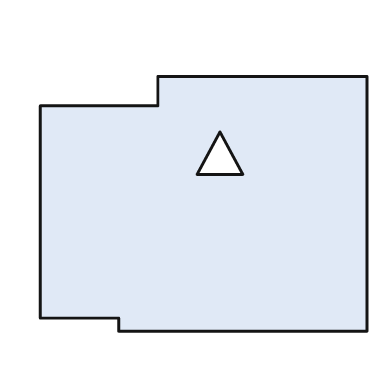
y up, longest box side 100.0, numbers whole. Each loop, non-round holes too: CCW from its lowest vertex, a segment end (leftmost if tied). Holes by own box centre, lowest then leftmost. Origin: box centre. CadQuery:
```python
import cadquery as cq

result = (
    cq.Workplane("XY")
    .moveTo(-26.0, -39.0)
    .lineTo(50.0, -39.0)
    .lineTo(50.0, 39.0)
    .lineTo(-14.0, 39.0)
    .lineTo(-14.0, 30.0)
    .lineTo(-50.0, 30.0)
    .lineTo(-50.0, -35.0)
    .lineTo(-26.0, -35.0)
    .close()
    .moveTo(-2.0, 9.0)
    .lineTo(12.0, 9.0)
    .lineTo(5.0, 22.0)
    .close()
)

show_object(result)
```